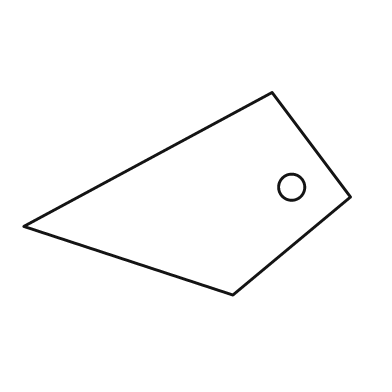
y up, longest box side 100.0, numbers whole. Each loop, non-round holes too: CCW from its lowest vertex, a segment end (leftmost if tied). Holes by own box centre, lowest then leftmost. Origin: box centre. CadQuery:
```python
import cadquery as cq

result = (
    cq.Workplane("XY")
    .moveTo(14.0, -31.0)
    .lineTo(50.0, -1.0)
    .lineTo(26.0, 31.0)
    .lineTo(-50.0, -10.0)
    .close()
    .moveTo(32.0, 2.0)
    .circle(4.0)
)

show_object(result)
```